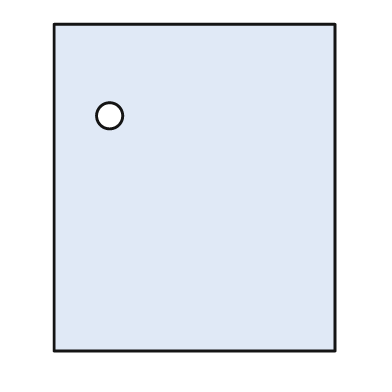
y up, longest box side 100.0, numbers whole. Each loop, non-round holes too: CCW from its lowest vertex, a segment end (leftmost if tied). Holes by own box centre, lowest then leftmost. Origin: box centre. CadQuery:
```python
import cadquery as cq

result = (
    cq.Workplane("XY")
    .moveTo(-43.0, -50.0)
    .lineTo(43.0, -50.0)
    .lineTo(43.0, 50.0)
    .lineTo(-43.0, 50.0)
    .close()
    .moveTo(-26.0, 22.0)
    .circle(4.0)
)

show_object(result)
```